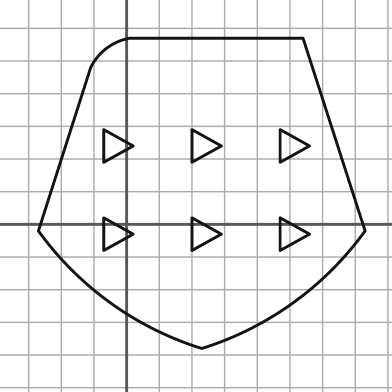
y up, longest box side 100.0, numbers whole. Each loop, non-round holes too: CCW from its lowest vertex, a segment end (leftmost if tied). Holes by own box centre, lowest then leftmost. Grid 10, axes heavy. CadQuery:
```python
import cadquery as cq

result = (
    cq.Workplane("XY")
    .moveTo(23.0, -38.0)
    .threePointArc((51.0, -24.0), (73.0, -2.0))
    .lineTo(54.0, 57.0)
    .lineTo(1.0, 57.0)
    .threePointArc((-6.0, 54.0), (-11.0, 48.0))
    .lineTo(-27.0, -2.0)
    .threePointArc((-5.0, -24.0), (23.0, -38.0))
    .close()
    .moveTo(-7.0, -8.0)
    .lineTo(2.0, -3.0)
    .lineTo(-7.0, 2.0)
    .close()
    .moveTo(20.0, -8.0)
    .lineTo(29.0, -3.0)
    .lineTo(20.0, 2.0)
    .close()
    .moveTo(47.0, -8.0)
    .lineTo(56.0, -3.0)
    .lineTo(47.0, 2.0)
    .close()
    .moveTo(-7.0, 19.0)
    .lineTo(2.0, 24.0)
    .lineTo(-7.0, 29.0)
    .close()
    .moveTo(20.0, 19.0)
    .lineTo(29.0, 24.0)
    .lineTo(20.0, 29.0)
    .close()
    .moveTo(47.0, 19.0)
    .lineTo(56.0, 24.0)
    .lineTo(47.0, 29.0)
    .close()
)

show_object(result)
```